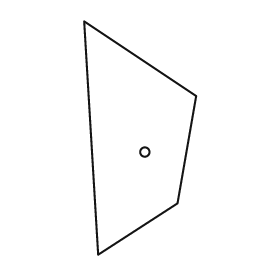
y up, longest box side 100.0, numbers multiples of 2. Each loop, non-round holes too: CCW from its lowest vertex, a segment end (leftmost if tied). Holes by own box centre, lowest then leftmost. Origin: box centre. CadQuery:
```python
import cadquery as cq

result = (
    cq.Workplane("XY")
    .moveTo(-18.0, -50.0)
    .lineTo(16.0, -28.0)
    .lineTo(24.0, 18.0)
    .lineTo(-24.0, 50.0)
    .close()
    .moveTo(2.0, -6.0)
    .circle(2.0)
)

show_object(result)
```